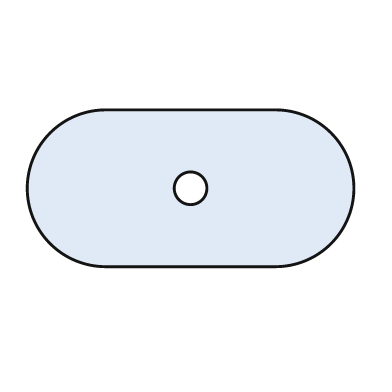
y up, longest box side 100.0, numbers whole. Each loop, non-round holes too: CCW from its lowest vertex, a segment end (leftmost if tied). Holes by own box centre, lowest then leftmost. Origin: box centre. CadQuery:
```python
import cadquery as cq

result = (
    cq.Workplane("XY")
    .moveTo(-26.0, -24.0)
    .lineTo(26.0, -24.0)
    .threePointArc((50.0, 0.0), (26.0, 24.0))
    .lineTo(-26.0, 24.0)
    .threePointArc((-50.0, 0.0), (-26.0, -24.0))
    .close()
    .moveTo(0.0, 0.0)
    .circle(5.0)
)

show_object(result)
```